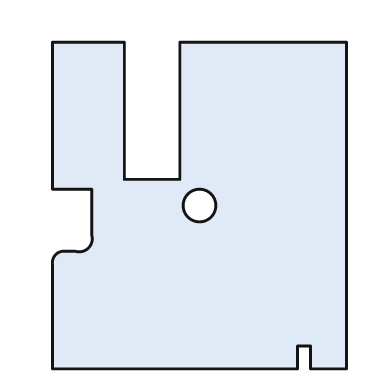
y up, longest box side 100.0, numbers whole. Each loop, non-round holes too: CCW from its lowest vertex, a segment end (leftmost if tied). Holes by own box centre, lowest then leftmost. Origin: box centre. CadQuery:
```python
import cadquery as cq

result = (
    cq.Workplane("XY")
    .moveTo(-45.0, -50.0)
    .lineTo(30.0, -50.0)
    .lineTo(30.0, -43.0)
    .lineTo(34.0, -43.0)
    .lineTo(34.0, -50.0)
    .lineTo(45.0, -50.0)
    .lineTo(45.0, 50.0)
    .lineTo(-6.0, 50.0)
    .lineTo(-6.0, 8.0)
    .lineTo(-23.0, 8.0)
    .lineTo(-23.0, 50.0)
    .lineTo(-45.0, 50.0)
    .lineTo(-45.0, 5.0)
    .lineTo(-33.0, 5.0)
    .lineTo(-33.0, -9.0)
    .threePointArc((-34.0, -13.0), (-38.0, -14.0))
    .lineTo(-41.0, -14.0)
    .threePointArc((-44.0, -15.0), (-45.0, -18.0))
    .close()
    .moveTo(0.0, 0.0)
    .circle(5.0)
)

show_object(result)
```